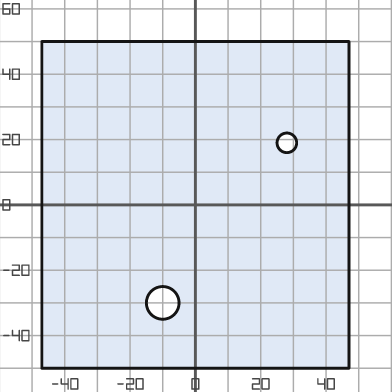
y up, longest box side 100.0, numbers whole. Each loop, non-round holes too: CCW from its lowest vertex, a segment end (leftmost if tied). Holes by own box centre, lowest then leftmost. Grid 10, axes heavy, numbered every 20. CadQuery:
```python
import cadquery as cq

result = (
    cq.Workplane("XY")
    .moveTo(-47.0, -50.0)
    .lineTo(47.0, -50.0)
    .lineTo(47.0, 50.0)
    .lineTo(-47.0, 50.0)
    .close()
    .moveTo(-10.0, -30.0)
    .circle(5.0)
    .moveTo(28.0, 19.0)
    .circle(3.0)
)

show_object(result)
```